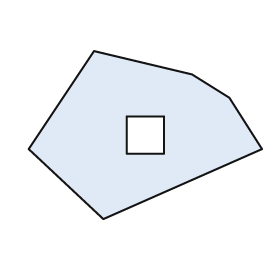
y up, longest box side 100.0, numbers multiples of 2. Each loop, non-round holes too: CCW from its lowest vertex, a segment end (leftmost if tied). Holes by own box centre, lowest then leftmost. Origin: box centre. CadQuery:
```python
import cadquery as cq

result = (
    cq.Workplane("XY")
    .moveTo(-18.0, -36.0)
    .lineTo(50.0, -6.0)
    .lineTo(36.0, 16.0)
    .lineTo(20.0, 26.0)
    .lineTo(-22.0, 36.0)
    .lineTo(-50.0, -6.0)
    .close()
    .moveTo(-8.0, -8.0)
    .lineTo(8.0, -8.0)
    .lineTo(8.0, 8.0)
    .lineTo(-8.0, 8.0)
    .close()
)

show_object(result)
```